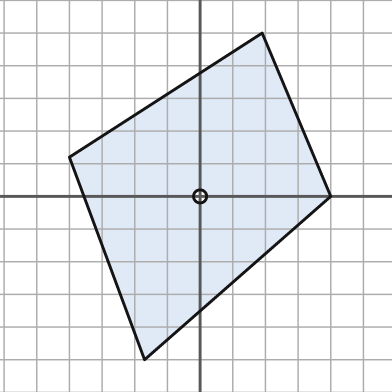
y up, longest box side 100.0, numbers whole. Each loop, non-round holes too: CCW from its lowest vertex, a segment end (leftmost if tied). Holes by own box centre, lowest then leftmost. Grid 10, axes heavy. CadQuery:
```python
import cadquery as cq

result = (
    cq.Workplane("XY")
    .moveTo(-17.0, -50.0)
    .lineTo(40.0, 0.0)
    .lineTo(19.0, 50.0)
    .lineTo(-40.0, 12.0)
    .close()
    .moveTo(0.0, 0.0)
    .circle(2.0)
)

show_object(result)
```